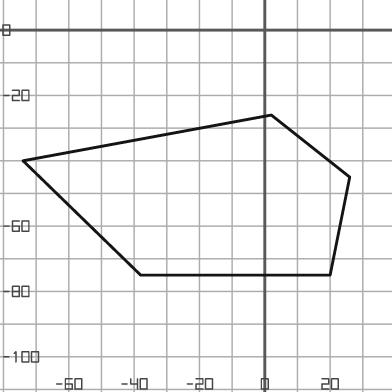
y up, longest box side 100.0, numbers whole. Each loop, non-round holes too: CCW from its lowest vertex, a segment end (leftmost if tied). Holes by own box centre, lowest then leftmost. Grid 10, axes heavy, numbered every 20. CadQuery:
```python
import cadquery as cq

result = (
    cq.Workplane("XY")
    .moveTo(-38.0, -75.0)
    .lineTo(20.0, -75.0)
    .lineTo(26.0, -45.0)
    .lineTo(2.0, -26.0)
    .lineTo(-74.0, -40.0)
    .close()
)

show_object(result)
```